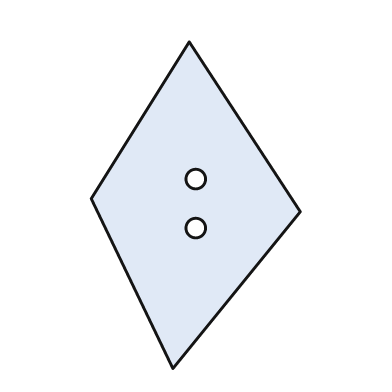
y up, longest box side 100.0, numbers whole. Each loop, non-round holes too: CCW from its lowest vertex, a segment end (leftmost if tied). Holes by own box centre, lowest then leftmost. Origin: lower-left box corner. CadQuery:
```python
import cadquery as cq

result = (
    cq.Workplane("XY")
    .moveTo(25.0, 0.0)
    .lineTo(64.0, 48.0)
    .lineTo(30.0, 100.0)
    .lineTo(0.0, 52.0)
    .close()
    .moveTo(32.0, 43.0)
    .circle(3.0)
    .moveTo(32.0, 58.0)
    .circle(3.0)
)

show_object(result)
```